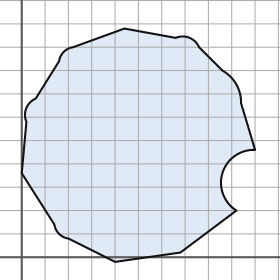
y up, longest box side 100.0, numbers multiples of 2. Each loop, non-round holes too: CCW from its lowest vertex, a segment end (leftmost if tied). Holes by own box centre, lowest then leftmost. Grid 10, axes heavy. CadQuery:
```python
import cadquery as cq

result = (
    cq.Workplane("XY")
    .moveTo(40.0, -2.0)
    .lineTo(68.0, 2.0)
    .lineTo(92.0, 20.0)
    .threePointArc((86.0, 36.0), (100.0, 46.0))
    .lineTo(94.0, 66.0)
    .threePointArc((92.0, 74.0), (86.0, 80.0))
    .lineTo(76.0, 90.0)
    .threePointArc((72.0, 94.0), (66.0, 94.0))
    .lineTo(44.0, 98.0)
    .lineTo(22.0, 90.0)
    .threePointArc((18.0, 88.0), (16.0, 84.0))
    .lineTo(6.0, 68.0)
    .threePointArc((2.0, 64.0), (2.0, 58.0))
    .lineTo(0.0, 36.0)
    .lineTo(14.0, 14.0)
    .threePointArc((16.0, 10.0), (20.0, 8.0))
    .close()
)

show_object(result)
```